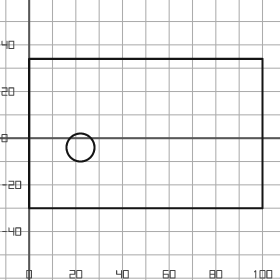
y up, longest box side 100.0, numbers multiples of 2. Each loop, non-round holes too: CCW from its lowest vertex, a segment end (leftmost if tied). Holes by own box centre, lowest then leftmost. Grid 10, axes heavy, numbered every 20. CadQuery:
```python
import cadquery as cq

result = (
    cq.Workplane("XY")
    .moveTo(0.0, -30.0)
    .lineTo(100.0, -30.0)
    .lineTo(100.0, 34.0)
    .lineTo(0.0, 34.0)
    .close()
    .moveTo(22.0, -4.0)
    .circle(6.0)
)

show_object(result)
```